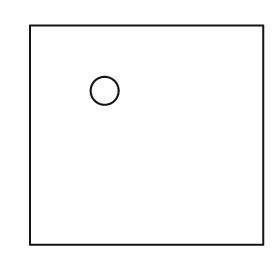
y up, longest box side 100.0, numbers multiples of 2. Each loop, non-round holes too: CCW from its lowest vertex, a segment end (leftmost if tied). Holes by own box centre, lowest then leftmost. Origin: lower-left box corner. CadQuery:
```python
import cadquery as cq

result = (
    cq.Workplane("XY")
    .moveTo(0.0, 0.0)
    .lineTo(100.0, 0.0)
    .lineTo(100.0, 94.0)
    .lineTo(0.0, 94.0)
    .close()
    .moveTo(32.0, 66.0)
    .circle(6.0)
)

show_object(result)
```